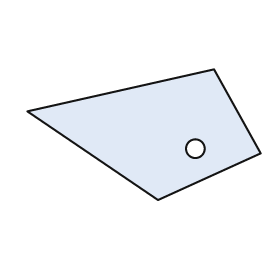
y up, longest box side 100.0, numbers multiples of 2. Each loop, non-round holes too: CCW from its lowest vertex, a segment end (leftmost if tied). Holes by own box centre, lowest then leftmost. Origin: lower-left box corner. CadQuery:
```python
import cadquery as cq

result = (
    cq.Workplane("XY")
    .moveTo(56.0, 0.0)
    .lineTo(100.0, 20.0)
    .lineTo(80.0, 56.0)
    .lineTo(0.0, 38.0)
    .close()
    .moveTo(72.0, 22.0)
    .circle(4.0)
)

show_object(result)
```